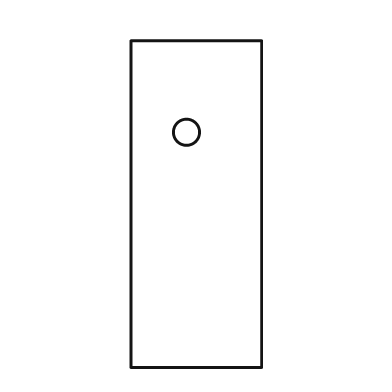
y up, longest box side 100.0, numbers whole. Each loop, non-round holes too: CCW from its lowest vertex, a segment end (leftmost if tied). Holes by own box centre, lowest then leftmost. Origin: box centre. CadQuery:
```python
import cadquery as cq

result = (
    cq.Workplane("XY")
    .moveTo(-20.0, -50.0)
    .lineTo(20.0, -50.0)
    .lineTo(20.0, 50.0)
    .lineTo(-20.0, 50.0)
    .close()
    .moveTo(-3.0, 22.0)
    .circle(4.0)
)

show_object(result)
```